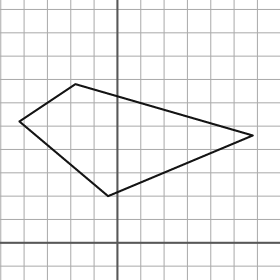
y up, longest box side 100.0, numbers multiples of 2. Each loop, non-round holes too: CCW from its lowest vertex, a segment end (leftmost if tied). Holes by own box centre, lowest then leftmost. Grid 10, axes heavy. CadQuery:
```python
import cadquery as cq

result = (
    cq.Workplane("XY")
    .moveTo(-4.0, 20.0)
    .lineTo(58.0, 46.0)
    .lineTo(-18.0, 68.0)
    .lineTo(-42.0, 52.0)
    .close()
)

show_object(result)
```